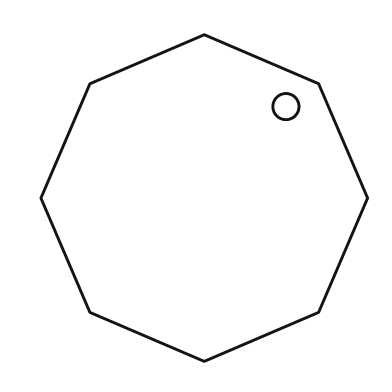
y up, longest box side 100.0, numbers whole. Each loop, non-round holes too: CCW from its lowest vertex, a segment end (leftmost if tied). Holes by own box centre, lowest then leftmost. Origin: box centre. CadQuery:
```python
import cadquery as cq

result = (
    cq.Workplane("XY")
    .moveTo(0.0, -50.0)
    .lineTo(35.0, -35.0)
    .lineTo(50.0, 0.0)
    .lineTo(35.0, 35.0)
    .lineTo(0.0, 50.0)
    .lineTo(-35.0, 35.0)
    .lineTo(-50.0, 0.0)
    .lineTo(-35.0, -35.0)
    .close()
    .moveTo(25.0, 28.0)
    .circle(4.0)
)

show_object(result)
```